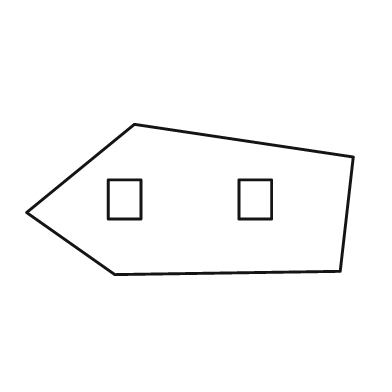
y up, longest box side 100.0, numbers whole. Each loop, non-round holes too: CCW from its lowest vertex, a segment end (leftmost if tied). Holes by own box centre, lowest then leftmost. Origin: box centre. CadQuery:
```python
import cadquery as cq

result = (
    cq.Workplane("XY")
    .moveTo(-23.0, -23.0)
    .lineTo(46.0, -22.0)
    .lineTo(50.0, 13.0)
    .lineTo(-17.0, 23.0)
    .lineTo(-50.0, -4.0)
    .close()
    .moveTo(-25.0, -6.0)
    .lineTo(-15.0, -6.0)
    .lineTo(-15.0, 6.0)
    .lineTo(-25.0, 6.0)
    .close()
    .moveTo(15.0, -6.0)
    .lineTo(25.0, -6.0)
    .lineTo(25.0, 6.0)
    .lineTo(15.0, 6.0)
    .close()
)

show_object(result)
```